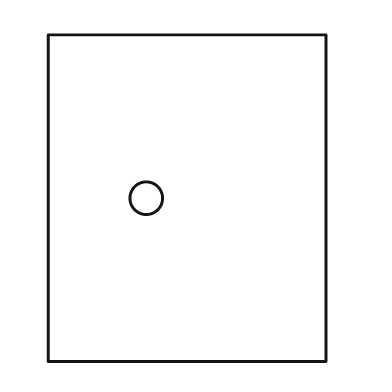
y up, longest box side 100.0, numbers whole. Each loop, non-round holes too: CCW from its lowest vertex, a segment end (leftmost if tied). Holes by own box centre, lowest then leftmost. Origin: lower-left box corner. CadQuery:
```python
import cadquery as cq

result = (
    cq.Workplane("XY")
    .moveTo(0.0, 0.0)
    .lineTo(85.0, 0.0)
    .lineTo(85.0, 100.0)
    .lineTo(0.0, 100.0)
    .close()
    .moveTo(30.0, 50.0)
    .circle(5.0)
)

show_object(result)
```